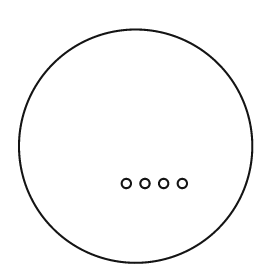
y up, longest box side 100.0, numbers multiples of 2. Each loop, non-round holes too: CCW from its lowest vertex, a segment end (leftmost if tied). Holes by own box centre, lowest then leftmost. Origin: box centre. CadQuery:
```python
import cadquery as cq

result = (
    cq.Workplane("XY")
    .moveTo(0.0, 0.0)
    .circle(50.0)
    .moveTo(-4.0, -16.0)
    .circle(2.0)
    .moveTo(4.0, -16.0)
    .circle(2.0)
    .moveTo(12.0, -16.0)
    .circle(2.0)
    .moveTo(20.0, -16.0)
    .circle(2.0)
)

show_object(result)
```